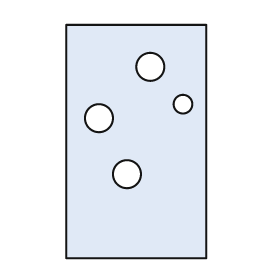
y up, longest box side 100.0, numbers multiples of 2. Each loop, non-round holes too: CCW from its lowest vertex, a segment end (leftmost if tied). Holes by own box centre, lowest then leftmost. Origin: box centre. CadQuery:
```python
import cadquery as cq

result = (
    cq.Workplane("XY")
    .moveTo(-30.0, -50.0)
    .lineTo(30.0, -50.0)
    .lineTo(30.0, 50.0)
    .lineTo(-30.0, 50.0)
    .close()
    .moveTo(-4.0, -14.0)
    .circle(6.0)
    .moveTo(-16.0, 10.0)
    .circle(6.0)
    .moveTo(20.0, 16.0)
    .circle(4.0)
    .moveTo(6.0, 32.0)
    .circle(6.0)
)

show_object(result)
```